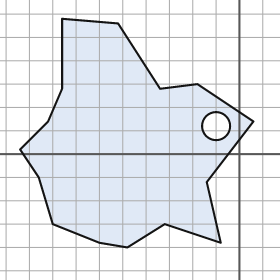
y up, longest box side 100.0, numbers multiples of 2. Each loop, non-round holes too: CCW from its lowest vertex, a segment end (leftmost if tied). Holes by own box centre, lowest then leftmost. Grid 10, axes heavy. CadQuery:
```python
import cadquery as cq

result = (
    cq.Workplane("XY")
    .moveTo(-48.0, -40.0)
    .lineTo(-32.0, -30.0)
    .lineTo(-8.0, -38.0)
    .lineTo(-14.0, -12.0)
    .lineTo(6.0, 14.0)
    .lineTo(-18.0, 30.0)
    .lineTo(-34.0, 28.0)
    .lineTo(-52.0, 56.0)
    .lineTo(-76.0, 58.0)
    .lineTo(-76.0, 28.0)
    .lineTo(-82.0, 14.0)
    .lineTo(-94.0, 2.0)
    .lineTo(-86.0, -10.0)
    .lineTo(-80.0, -30.0)
    .lineTo(-60.0, -38.0)
    .close()
    .moveTo(-10.0, 12.0)
    .circle(6.0)
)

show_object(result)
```